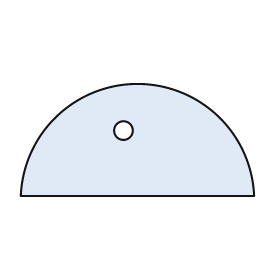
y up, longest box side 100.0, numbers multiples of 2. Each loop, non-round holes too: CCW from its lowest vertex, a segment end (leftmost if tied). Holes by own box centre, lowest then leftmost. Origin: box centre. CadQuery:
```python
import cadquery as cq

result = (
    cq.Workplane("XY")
    .moveTo(-50.0, -24.0)
    .lineTo(50.0, -24.0)
    .threePointArc((0.0, 24.0), (-50.0, -24.0))
    .close()
    .moveTo(-6.0, 4.0)
    .circle(4.0)
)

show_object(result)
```